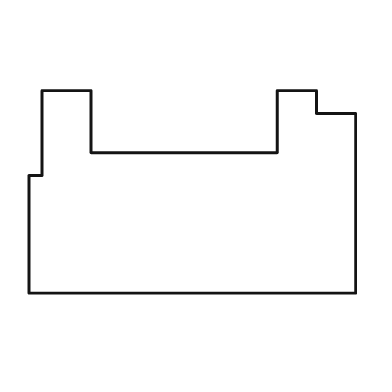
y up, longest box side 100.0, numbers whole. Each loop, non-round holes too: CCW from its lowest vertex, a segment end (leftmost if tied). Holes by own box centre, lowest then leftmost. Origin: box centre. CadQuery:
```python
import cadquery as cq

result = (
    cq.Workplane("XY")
    .moveTo(-50.0, -31.0)
    .lineTo(50.0, -31.0)
    .lineTo(50.0, 24.0)
    .lineTo(38.0, 24.0)
    .lineTo(38.0, 31.0)
    .lineTo(26.0, 31.0)
    .lineTo(26.0, 12.0)
    .lineTo(-31.0, 12.0)
    .lineTo(-31.0, 31.0)
    .lineTo(-46.0, 31.0)
    .lineTo(-46.0, 5.0)
    .lineTo(-50.0, 5.0)
    .close()
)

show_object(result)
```